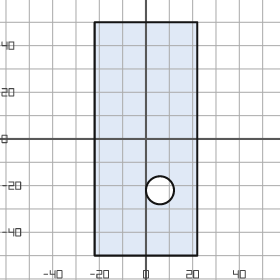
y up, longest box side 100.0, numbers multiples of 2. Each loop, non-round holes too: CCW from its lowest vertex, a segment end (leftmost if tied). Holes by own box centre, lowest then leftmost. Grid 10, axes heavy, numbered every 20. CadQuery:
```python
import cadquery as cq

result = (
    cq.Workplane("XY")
    .moveTo(-22.0, -50.0)
    .lineTo(22.0, -50.0)
    .lineTo(22.0, 50.0)
    .lineTo(-22.0, 50.0)
    .close()
    .moveTo(6.0, -22.0)
    .circle(6.0)
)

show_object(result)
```